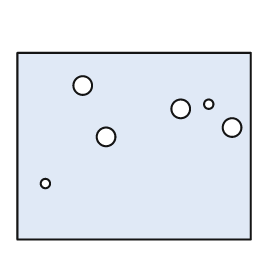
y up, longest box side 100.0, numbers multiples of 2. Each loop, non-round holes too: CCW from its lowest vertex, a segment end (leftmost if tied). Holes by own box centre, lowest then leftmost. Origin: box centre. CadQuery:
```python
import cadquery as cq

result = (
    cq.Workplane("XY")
    .moveTo(-50.0, -40.0)
    .lineTo(50.0, -40.0)
    .lineTo(50.0, 40.0)
    .lineTo(-50.0, 40.0)
    .close()
    .moveTo(-38.0, -16.0)
    .circle(2.0)
    .moveTo(-12.0, 4.0)
    .circle(4.0)
    .moveTo(42.0, 8.0)
    .circle(4.0)
    .moveTo(20.0, 16.0)
    .circle(4.0)
    .moveTo(32.0, 18.0)
    .circle(2.0)
    .moveTo(-22.0, 26.0)
    .circle(4.0)
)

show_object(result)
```